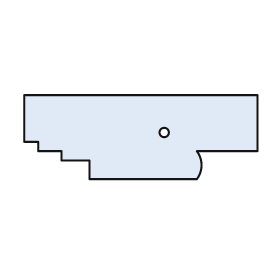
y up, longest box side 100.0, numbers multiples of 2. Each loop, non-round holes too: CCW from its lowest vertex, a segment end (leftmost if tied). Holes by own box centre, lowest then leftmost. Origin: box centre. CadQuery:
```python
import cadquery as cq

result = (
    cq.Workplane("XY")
    .moveTo(-22.0, -18.0)
    .lineTo(24.0, -18.0)
    .threePointArc((26.0, -12.0), (24.0, -6.0))
    .lineTo(50.0, -6.0)
    .lineTo(50.0, 18.0)
    .lineTo(-50.0, 18.0)
    .lineTo(-50.0, -2.0)
    .lineTo(-44.0, -2.0)
    .lineTo(-44.0, -6.0)
    .lineTo(-34.0, -6.0)
    .lineTo(-34.0, -10.0)
    .lineTo(-22.0, -10.0)
    .close()
    .moveTo(10.0, 2.0)
    .circle(2.0)
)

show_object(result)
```